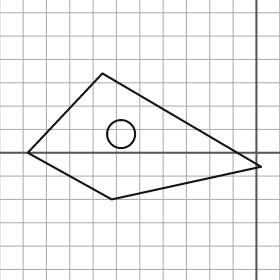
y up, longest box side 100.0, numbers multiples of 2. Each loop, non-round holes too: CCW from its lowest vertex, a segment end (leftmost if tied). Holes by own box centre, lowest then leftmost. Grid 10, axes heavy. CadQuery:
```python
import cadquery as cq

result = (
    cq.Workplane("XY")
    .moveTo(-62.0, -20.0)
    .lineTo(2.0, -6.0)
    .lineTo(-66.0, 34.0)
    .lineTo(-98.0, 0.0)
    .close()
    .moveTo(-58.0, 8.0)
    .circle(6.0)
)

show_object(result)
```